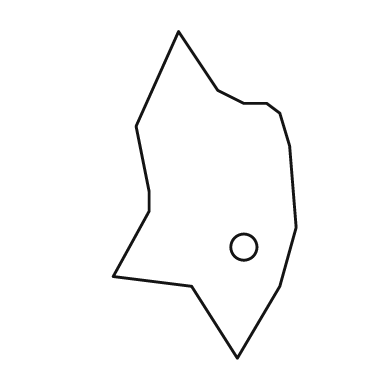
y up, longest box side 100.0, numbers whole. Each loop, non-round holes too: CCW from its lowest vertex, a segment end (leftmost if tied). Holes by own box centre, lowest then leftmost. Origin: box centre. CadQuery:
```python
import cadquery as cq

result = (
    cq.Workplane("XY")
    .moveTo(10.0, -50.0)
    .lineTo(23.0, -28.0)
    .lineTo(28.0, -10.0)
    .lineTo(26.0, 15.0)
    .lineTo(23.0, 25.0)
    .lineTo(19.0, 28.0)
    .lineTo(12.0, 28.0)
    .lineTo(4.0, 32.0)
    .lineTo(-8.0, 50.0)
    .lineTo(-21.0, 21.0)
    .lineTo(-17.0, 1.0)
    .lineTo(-17.0, -5.0)
    .lineTo(-28.0, -25.0)
    .lineTo(-4.0, -28.0)
    .close()
    .moveTo(12.0, -16.0)
    .circle(4.0)
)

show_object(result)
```